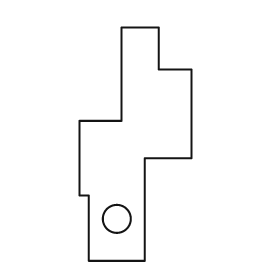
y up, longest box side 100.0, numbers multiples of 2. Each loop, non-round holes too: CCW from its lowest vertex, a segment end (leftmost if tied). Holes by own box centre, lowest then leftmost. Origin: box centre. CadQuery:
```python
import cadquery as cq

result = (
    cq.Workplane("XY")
    .moveTo(-20.0, -50.0)
    .lineTo(4.0, -50.0)
    .lineTo(4.0, -6.0)
    .lineTo(24.0, -6.0)
    .lineTo(24.0, 32.0)
    .lineTo(10.0, 32.0)
    .lineTo(10.0, 50.0)
    .lineTo(-6.0, 50.0)
    .lineTo(-6.0, 10.0)
    .lineTo(-24.0, 10.0)
    .lineTo(-24.0, -22.0)
    .lineTo(-20.0, -22.0)
    .close()
    .moveTo(-8.0, -32.0)
    .circle(6.0)
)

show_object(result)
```